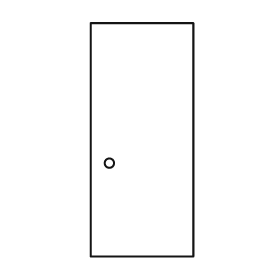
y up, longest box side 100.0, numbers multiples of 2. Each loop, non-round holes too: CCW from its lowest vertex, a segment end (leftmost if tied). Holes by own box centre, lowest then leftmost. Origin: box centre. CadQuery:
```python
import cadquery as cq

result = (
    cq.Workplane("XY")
    .moveTo(-22.0, -50.0)
    .lineTo(22.0, -50.0)
    .lineTo(22.0, 50.0)
    .lineTo(-22.0, 50.0)
    .close()
    .moveTo(-14.0, -10.0)
    .circle(2.0)
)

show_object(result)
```